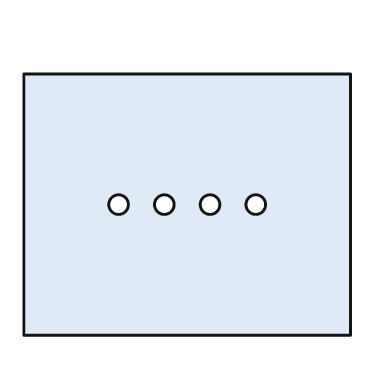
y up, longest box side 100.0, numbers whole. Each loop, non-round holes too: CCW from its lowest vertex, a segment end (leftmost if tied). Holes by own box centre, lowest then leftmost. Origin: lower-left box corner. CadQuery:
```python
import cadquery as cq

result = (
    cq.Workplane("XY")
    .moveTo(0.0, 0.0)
    .lineTo(100.0, 0.0)
    .lineTo(100.0, 80.0)
    .lineTo(0.0, 80.0)
    .close()
    .moveTo(29.0, 40.0)
    .circle(3.0)
    .moveTo(43.0, 40.0)
    .circle(3.0)
    .moveTo(57.0, 40.0)
    .circle(3.0)
    .moveTo(71.0, 40.0)
    .circle(3.0)
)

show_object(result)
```